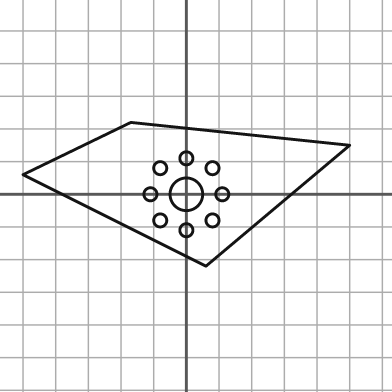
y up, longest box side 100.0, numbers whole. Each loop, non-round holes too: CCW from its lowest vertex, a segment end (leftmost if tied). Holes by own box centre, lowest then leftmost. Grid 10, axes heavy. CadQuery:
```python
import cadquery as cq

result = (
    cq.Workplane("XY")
    .moveTo(6.0, -22.0)
    .lineTo(50.0, 15.0)
    .lineTo(-17.0, 22.0)
    .lineTo(-50.0, 6.0)
    .close()
    .moveTo(0.0, -11.0)
    .circle(2.0)
    .moveTo(-8.0, -8.0)
    .circle(2.0)
    .moveTo(8.0, -8.0)
    .circle(2.0)
    .moveTo(-11.0, 0.0)
    .circle(2.0)
    .moveTo(0.0, 0.0)
    .circle(5.0)
    .moveTo(11.0, 0.0)
    .circle(2.0)
    .moveTo(-8.0, 8.0)
    .circle(2.0)
    .moveTo(8.0, 8.0)
    .circle(2.0)
    .moveTo(0.0, 11.0)
    .circle(2.0)
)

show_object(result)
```